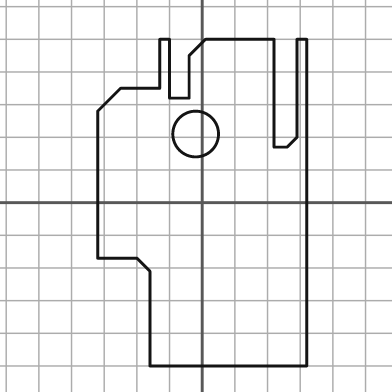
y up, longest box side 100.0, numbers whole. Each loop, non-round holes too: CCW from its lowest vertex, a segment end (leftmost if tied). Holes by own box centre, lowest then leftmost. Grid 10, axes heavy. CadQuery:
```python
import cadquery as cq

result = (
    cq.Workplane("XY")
    .moveTo(-16.0, -50.0)
    .lineTo(32.0, -50.0)
    .lineTo(32.0, 50.0)
    .lineTo(29.0, 50.0)
    .lineTo(29.0, 20.0)
    .lineTo(26.0, 17.0)
    .lineTo(22.0, 17.0)
    .lineTo(22.0, 50.0)
    .lineTo(1.0, 50.0)
    .lineTo(-4.0, 45.0)
    .lineTo(-4.0, 32.0)
    .lineTo(-10.0, 32.0)
    .lineTo(-10.0, 50.0)
    .lineTo(-13.0, 50.0)
    .lineTo(-13.0, 35.0)
    .lineTo(-25.0, 35.0)
    .lineTo(-32.0, 28.0)
    .lineTo(-32.0, -17.0)
    .lineTo(-20.0, -17.0)
    .lineTo(-16.0, -21.0)
    .close()
    .moveTo(-2.0, 21.0)
    .circle(7.0)
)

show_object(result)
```